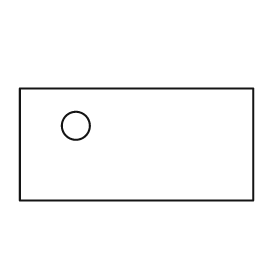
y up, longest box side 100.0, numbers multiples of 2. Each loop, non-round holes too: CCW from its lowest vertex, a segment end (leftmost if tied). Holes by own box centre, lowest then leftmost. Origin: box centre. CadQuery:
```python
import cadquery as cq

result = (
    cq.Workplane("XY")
    .moveTo(-50.0, -24.0)
    .lineTo(50.0, -24.0)
    .lineTo(50.0, 24.0)
    .lineTo(-50.0, 24.0)
    .close()
    .moveTo(-26.0, 8.0)
    .circle(6.0)
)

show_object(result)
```